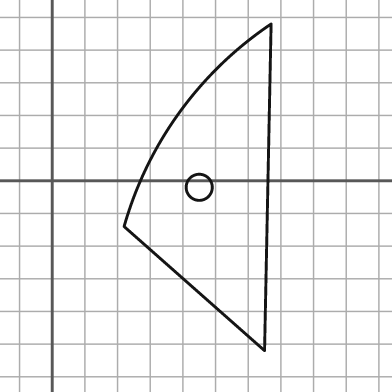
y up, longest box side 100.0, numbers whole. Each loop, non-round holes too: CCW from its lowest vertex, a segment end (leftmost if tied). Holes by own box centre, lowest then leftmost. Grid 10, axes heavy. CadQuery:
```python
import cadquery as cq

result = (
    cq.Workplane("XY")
    .moveTo(65.0, -52.0)
    .lineTo(67.0, 48.0)
    .threePointArc((39.0, 21.0), (22.0, -14.0))
    .close()
    .moveTo(45.0, -2.0)
    .circle(4.0)
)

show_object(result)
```